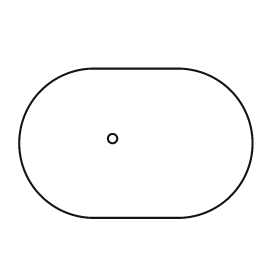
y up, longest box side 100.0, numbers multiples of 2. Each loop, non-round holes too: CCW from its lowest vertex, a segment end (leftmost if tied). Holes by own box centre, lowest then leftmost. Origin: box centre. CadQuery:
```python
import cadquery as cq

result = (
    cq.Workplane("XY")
    .moveTo(-18.0, -32.0)
    .lineTo(18.0, -32.0)
    .threePointArc((50.0, 0.0), (18.0, 32.0))
    .lineTo(-18.0, 32.0)
    .threePointArc((-50.0, 0.0), (-18.0, -32.0))
    .close()
    .moveTo(-10.0, 2.0)
    .circle(2.0)
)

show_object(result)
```